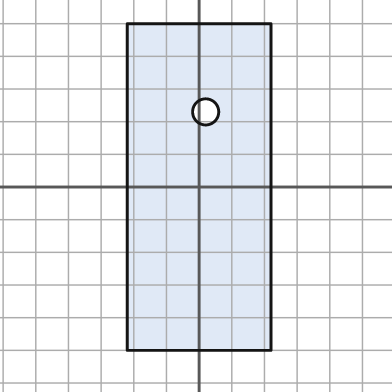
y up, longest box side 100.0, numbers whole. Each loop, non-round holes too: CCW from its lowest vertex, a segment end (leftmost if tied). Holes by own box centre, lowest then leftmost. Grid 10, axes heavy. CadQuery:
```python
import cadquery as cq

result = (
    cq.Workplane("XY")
    .moveTo(-22.0, -50.0)
    .lineTo(22.0, -50.0)
    .lineTo(22.0, 50.0)
    .lineTo(-22.0, 50.0)
    .close()
    .moveTo(2.0, 23.0)
    .circle(4.0)
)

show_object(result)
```